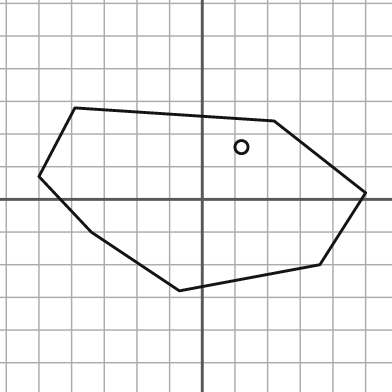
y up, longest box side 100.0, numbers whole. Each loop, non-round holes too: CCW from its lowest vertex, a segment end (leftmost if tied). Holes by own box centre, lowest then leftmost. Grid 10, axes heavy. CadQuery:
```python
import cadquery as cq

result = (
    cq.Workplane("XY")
    .moveTo(-7.0, -28.0)
    .lineTo(36.0, -20.0)
    .lineTo(50.0, 2.0)
    .lineTo(22.0, 24.0)
    .lineTo(-39.0, 28.0)
    .lineTo(-50.0, 7.0)
    .lineTo(-34.0, -10.0)
    .close()
    .moveTo(12.0, 16.0)
    .circle(2.0)
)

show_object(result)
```